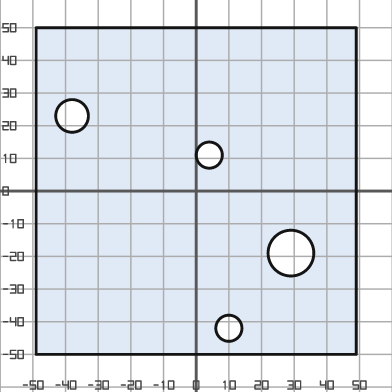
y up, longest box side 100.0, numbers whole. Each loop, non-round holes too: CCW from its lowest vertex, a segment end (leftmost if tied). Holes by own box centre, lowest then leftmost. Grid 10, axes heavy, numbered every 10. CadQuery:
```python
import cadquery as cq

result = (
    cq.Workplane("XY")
    .moveTo(-49.0, -50.0)
    .lineTo(49.0, -50.0)
    .lineTo(49.0, 50.0)
    .lineTo(-49.0, 50.0)
    .close()
    .moveTo(10.0, -42.0)
    .circle(4.0)
    .moveTo(29.0, -19.0)
    .circle(7.0)
    .moveTo(4.0, 11.0)
    .circle(4.0)
    .moveTo(-38.0, 23.0)
    .circle(5.0)
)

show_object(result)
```